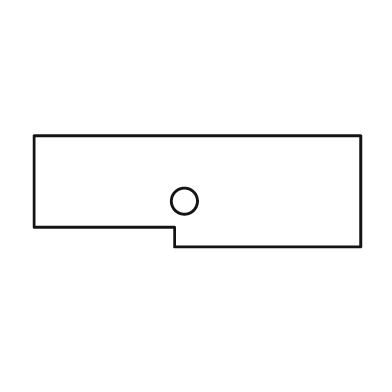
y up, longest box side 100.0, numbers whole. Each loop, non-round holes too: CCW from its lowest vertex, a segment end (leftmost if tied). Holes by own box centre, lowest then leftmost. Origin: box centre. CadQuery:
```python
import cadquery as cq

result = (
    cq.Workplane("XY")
    .moveTo(-7.0, -17.0)
    .lineTo(50.0, -17.0)
    .lineTo(50.0, 17.0)
    .lineTo(-50.0, 17.0)
    .lineTo(-50.0, -11.0)
    .lineTo(-7.0, -11.0)
    .close()
    .moveTo(-4.0, -3.0)
    .circle(4.0)
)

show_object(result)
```